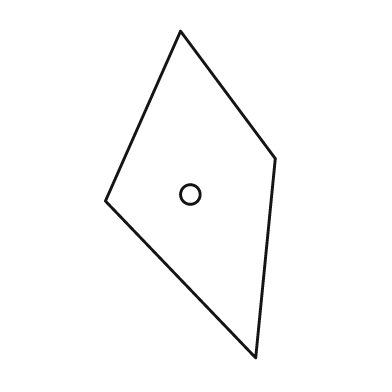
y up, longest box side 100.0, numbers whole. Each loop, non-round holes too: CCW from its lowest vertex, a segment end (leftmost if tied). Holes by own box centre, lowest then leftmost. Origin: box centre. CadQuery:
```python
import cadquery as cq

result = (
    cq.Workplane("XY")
    .moveTo(20.0, -50.0)
    .lineTo(26.0, 11.0)
    .lineTo(-3.0, 50.0)
    .lineTo(-26.0, -2.0)
    .close()
    .moveTo(0.0, 0.0)
    .circle(3.0)
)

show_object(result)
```